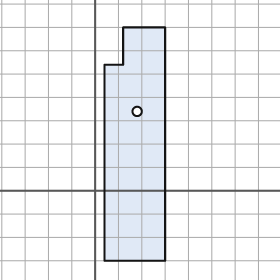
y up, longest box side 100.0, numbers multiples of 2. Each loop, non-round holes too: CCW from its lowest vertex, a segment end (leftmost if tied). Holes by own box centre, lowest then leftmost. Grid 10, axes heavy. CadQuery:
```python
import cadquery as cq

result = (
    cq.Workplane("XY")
    .moveTo(4.0, -30.0)
    .lineTo(30.0, -30.0)
    .lineTo(30.0, 70.0)
    .lineTo(12.0, 70.0)
    .lineTo(12.0, 54.0)
    .lineTo(4.0, 54.0)
    .close()
    .moveTo(18.0, 34.0)
    .circle(2.0)
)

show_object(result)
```